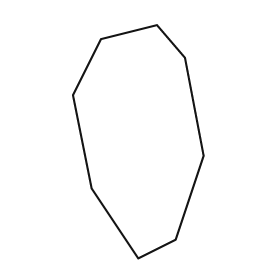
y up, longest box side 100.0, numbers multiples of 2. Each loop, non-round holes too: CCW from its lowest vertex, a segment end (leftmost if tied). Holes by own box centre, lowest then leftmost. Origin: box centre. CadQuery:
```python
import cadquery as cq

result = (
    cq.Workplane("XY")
    .moveTo(0.0, -50.0)
    .lineTo(16.0, -42.0)
    .lineTo(28.0, -6.0)
    .lineTo(20.0, 36.0)
    .lineTo(8.0, 50.0)
    .lineTo(-16.0, 44.0)
    .lineTo(-28.0, 20.0)
    .lineTo(-20.0, -20.0)
    .close()
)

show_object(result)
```